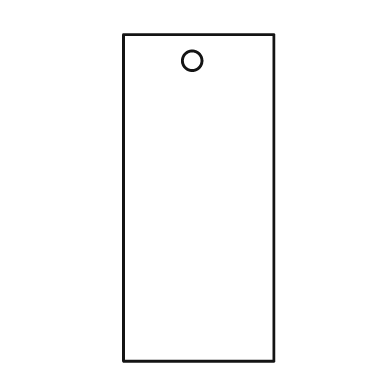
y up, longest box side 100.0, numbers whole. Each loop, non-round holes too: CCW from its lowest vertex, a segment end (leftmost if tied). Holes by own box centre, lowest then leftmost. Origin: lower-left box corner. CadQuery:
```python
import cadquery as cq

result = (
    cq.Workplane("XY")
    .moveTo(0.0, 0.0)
    .lineTo(46.0, 0.0)
    .lineTo(46.0, 100.0)
    .lineTo(0.0, 100.0)
    .close()
    .moveTo(21.0, 92.0)
    .circle(3.0)
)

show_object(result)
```